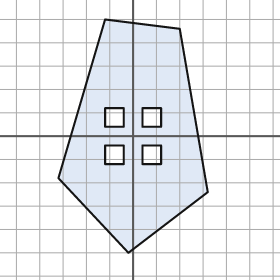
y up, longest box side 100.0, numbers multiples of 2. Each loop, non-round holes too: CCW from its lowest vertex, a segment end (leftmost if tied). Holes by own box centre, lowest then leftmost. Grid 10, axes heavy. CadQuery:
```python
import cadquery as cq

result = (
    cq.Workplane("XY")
    .moveTo(-2.0, -50.0)
    .lineTo(32.0, -24.0)
    .lineTo(20.0, 46.0)
    .lineTo(-12.0, 50.0)
    .lineTo(-32.0, -18.0)
    .close()
    .moveTo(-12.0, -12.0)
    .lineTo(-4.0, -12.0)
    .lineTo(-4.0, -4.0)
    .lineTo(-12.0, -4.0)
    .close()
    .moveTo(4.0, -12.0)
    .lineTo(12.0, -12.0)
    .lineTo(12.0, -4.0)
    .lineTo(4.0, -4.0)
    .close()
    .moveTo(-12.0, 4.0)
    .lineTo(-4.0, 4.0)
    .lineTo(-4.0, 12.0)
    .lineTo(-12.0, 12.0)
    .close()
    .moveTo(4.0, 4.0)
    .lineTo(12.0, 4.0)
    .lineTo(12.0, 12.0)
    .lineTo(4.0, 12.0)
    .close()
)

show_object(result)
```